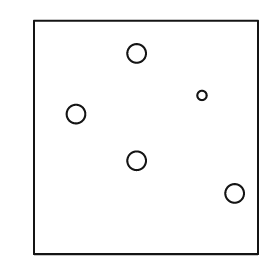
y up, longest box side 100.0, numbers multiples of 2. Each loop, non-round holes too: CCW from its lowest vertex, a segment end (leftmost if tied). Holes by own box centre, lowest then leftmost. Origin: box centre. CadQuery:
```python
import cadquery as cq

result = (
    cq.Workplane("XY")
    .moveTo(-48.0, -50.0)
    .lineTo(48.0, -50.0)
    .lineTo(48.0, 50.0)
    .lineTo(-48.0, 50.0)
    .close()
    .moveTo(38.0, -24.0)
    .circle(4.0)
    .moveTo(-4.0, -10.0)
    .circle(4.0)
    .moveTo(-30.0, 10.0)
    .circle(4.0)
    .moveTo(24.0, 18.0)
    .circle(2.0)
    .moveTo(-4.0, 36.0)
    .circle(4.0)
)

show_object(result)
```